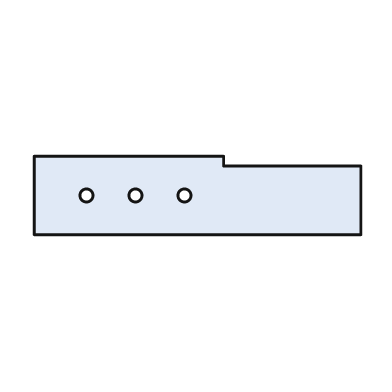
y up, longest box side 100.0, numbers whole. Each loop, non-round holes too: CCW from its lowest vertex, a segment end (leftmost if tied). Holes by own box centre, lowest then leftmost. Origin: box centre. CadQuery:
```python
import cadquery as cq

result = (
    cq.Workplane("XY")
    .moveTo(-50.0, -12.0)
    .lineTo(50.0, -12.0)
    .lineTo(50.0, 9.0)
    .lineTo(8.0, 9.0)
    .lineTo(8.0, 12.0)
    .lineTo(-50.0, 12.0)
    .close()
    .moveTo(-34.0, 0.0)
    .circle(2.0)
    .moveTo(-19.0, 0.0)
    .circle(2.0)
    .moveTo(-4.0, 0.0)
    .circle(2.0)
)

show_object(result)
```